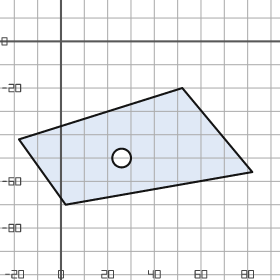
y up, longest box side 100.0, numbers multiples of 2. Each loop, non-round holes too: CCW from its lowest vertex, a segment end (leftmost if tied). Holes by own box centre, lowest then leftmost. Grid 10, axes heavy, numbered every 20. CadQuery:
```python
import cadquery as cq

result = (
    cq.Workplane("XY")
    .moveTo(2.0, -70.0)
    .lineTo(82.0, -56.0)
    .lineTo(52.0, -20.0)
    .lineTo(-18.0, -42.0)
    .close()
    .moveTo(26.0, -50.0)
    .circle(4.0)
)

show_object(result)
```